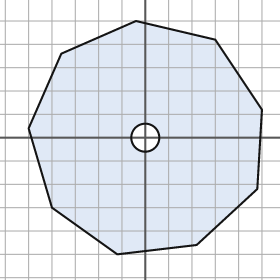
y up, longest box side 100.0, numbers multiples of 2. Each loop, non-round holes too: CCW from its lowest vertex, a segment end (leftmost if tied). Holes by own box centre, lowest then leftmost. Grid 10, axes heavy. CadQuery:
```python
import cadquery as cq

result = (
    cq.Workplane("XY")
    .moveTo(-12.0, -50.0)
    .lineTo(22.0, -46.0)
    .lineTo(48.0, -22.0)
    .lineTo(50.0, 12.0)
    .lineTo(30.0, 42.0)
    .lineTo(-4.0, 50.0)
    .lineTo(-36.0, 36.0)
    .lineTo(-50.0, 4.0)
    .lineTo(-40.0, -30.0)
    .close()
    .moveTo(0.0, 0.0)
    .circle(6.0)
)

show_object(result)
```